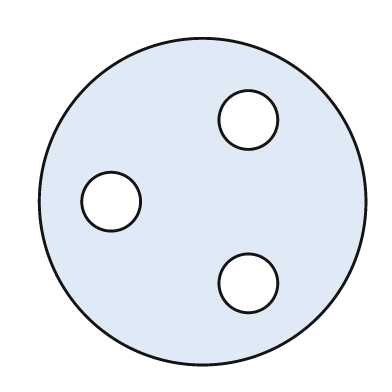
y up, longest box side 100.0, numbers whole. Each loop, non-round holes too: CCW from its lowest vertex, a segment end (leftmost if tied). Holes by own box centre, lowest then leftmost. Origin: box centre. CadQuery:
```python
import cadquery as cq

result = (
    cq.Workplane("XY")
    .moveTo(0.0, 0.0)
    .circle(50.0)
    .moveTo(14.0, -25.0)
    .circle(9.0)
    .moveTo(-28.0, 0.0)
    .circle(9.0)
    .moveTo(14.0, 25.0)
    .circle(9.0)
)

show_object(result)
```